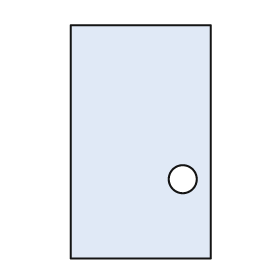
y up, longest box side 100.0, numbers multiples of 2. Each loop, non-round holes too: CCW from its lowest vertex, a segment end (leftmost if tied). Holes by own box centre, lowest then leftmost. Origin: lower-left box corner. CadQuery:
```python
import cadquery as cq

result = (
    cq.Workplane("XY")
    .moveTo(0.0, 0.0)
    .lineTo(60.0, 0.0)
    .lineTo(60.0, 100.0)
    .lineTo(0.0, 100.0)
    .close()
    .moveTo(48.0, 34.0)
    .circle(6.0)
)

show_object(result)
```